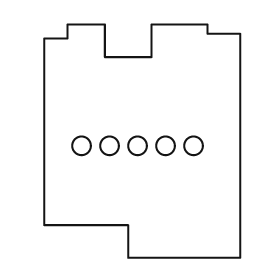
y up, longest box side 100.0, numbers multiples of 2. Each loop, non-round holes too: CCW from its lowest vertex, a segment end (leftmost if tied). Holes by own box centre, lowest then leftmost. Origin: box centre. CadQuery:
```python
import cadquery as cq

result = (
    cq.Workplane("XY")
    .moveTo(-6.0, -50.0)
    .lineTo(42.0, -50.0)
    .lineTo(42.0, 46.0)
    .lineTo(28.0, 46.0)
    .lineTo(28.0, 50.0)
    .lineTo(4.0, 50.0)
    .lineTo(4.0, 36.0)
    .lineTo(-16.0, 36.0)
    .lineTo(-16.0, 50.0)
    .lineTo(-32.0, 50.0)
    .lineTo(-32.0, 44.0)
    .lineTo(-42.0, 44.0)
    .lineTo(-42.0, -36.0)
    .lineTo(-6.0, -36.0)
    .close()
    .moveTo(-26.0, -2.0)
    .circle(4.0)
    .moveTo(-14.0, -2.0)
    .circle(4.0)
    .moveTo(-2.0, -2.0)
    .circle(4.0)
    .moveTo(10.0, -2.0)
    .circle(4.0)
    .moveTo(22.0, -2.0)
    .circle(4.0)
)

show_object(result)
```